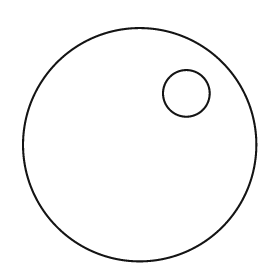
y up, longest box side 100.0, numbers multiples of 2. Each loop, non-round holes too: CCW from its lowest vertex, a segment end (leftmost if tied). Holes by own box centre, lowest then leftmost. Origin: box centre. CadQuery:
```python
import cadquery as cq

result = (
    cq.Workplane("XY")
    .moveTo(0.0, 0.0)
    .circle(50.0)
    .moveTo(20.0, 22.0)
    .circle(10.0)
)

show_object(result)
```